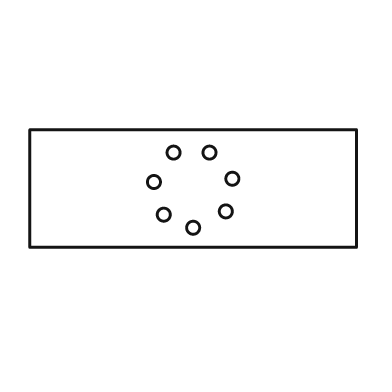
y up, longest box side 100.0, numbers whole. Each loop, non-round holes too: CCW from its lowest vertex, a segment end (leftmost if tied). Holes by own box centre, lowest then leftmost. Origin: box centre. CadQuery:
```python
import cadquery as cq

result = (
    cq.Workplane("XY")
    .moveTo(-50.0, -18.0)
    .lineTo(50.0, -18.0)
    .lineTo(50.0, 18.0)
    .lineTo(-50.0, 18.0)
    .close()
    .moveTo(0.0, -12.0)
    .circle(2.0)
    .moveTo(-9.0, -8.0)
    .circle(2.0)
    .moveTo(10.0, -7.0)
    .circle(2.0)
    .moveTo(-12.0, 2.0)
    .circle(2.0)
    .moveTo(12.0, 3.0)
    .circle(2.0)
    .moveTo(-6.0, 11.0)
    .circle(2.0)
    .moveTo(5.0, 11.0)
    .circle(2.0)
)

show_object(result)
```